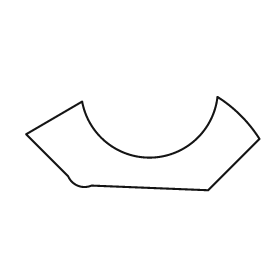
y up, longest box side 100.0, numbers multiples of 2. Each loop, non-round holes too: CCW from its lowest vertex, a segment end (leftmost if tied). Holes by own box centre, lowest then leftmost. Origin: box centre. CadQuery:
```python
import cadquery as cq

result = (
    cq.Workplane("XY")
    .moveTo(28.0, -20.0)
    .lineTo(50.0, 2.0)
    .threePointArc((42.0, 12.0), (32.0, 20.0))
    .threePointArc((4.0, -6.0), (-26.0, 18.0))
    .lineTo(-50.0, 4.0)
    .lineTo(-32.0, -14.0)
    .threePointArc((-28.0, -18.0), (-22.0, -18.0))
    .close()
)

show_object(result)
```